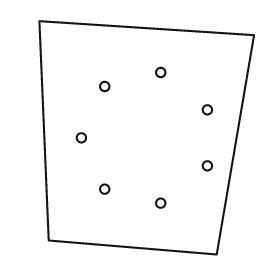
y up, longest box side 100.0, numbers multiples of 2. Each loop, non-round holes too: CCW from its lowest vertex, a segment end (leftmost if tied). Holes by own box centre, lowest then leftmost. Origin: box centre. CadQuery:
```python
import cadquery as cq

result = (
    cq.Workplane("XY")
    .moveTo(30.0, -50.0)
    .lineTo(46.0, 44.0)
    .lineTo(-46.0, 50.0)
    .lineTo(-42.0, -44.0)
    .close()
    .moveTo(6.0, -28.0)
    .circle(2.0)
    .moveTo(-18.0, -22.0)
    .circle(2.0)
    .moveTo(26.0, -12.0)
    .circle(2.0)
    .moveTo(-28.0, 0.0)
    .circle(2.0)
    .moveTo(26.0, 12.0)
    .circle(2.0)
    .moveTo(-18.0, 22.0)
    .circle(2.0)
    .moveTo(6.0, 28.0)
    .circle(2.0)
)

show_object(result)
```